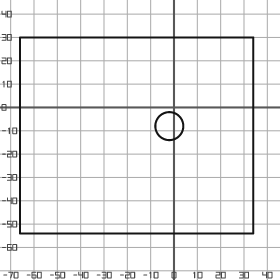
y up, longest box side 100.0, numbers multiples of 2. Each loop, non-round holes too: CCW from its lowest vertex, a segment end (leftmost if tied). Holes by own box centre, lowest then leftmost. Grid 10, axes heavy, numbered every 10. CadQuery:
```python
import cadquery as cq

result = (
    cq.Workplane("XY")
    .moveTo(-66.0, -54.0)
    .lineTo(34.0, -54.0)
    .lineTo(34.0, 30.0)
    .lineTo(-66.0, 30.0)
    .close()
    .moveTo(-2.0, -8.0)
    .circle(6.0)
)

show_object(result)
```